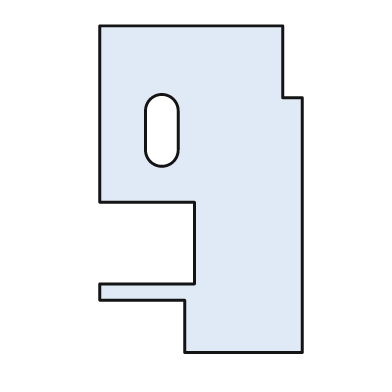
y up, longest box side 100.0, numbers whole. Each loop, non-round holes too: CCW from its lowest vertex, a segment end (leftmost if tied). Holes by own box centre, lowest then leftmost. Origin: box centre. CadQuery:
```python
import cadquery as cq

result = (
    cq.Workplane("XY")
    .moveTo(-5.0, -50.0)
    .lineTo(31.0, -50.0)
    .lineTo(31.0, 28.0)
    .lineTo(25.0, 28.0)
    .lineTo(25.0, 50.0)
    .lineTo(-31.0, 50.0)
    .lineTo(-31.0, -4.0)
    .lineTo(-2.0, -4.0)
    .lineTo(-2.0, -29.0)
    .lineTo(-31.0, -29.0)
    .lineTo(-31.0, -34.0)
    .lineTo(-5.0, -34.0)
    .close()
    .moveTo(-17.0, 12.0)
    .threePointArc((-12.0, 7.0), (-7.0, 12.0))
    .lineTo(-7.0, 24.0)
    .threePointArc((-12.0, 29.0), (-17.0, 24.0))
    .close()
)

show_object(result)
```